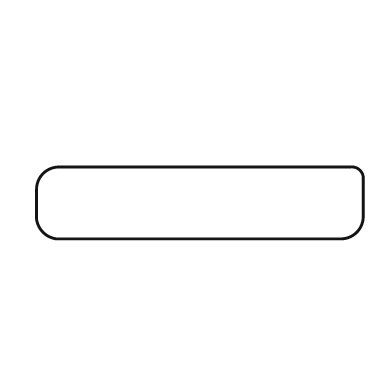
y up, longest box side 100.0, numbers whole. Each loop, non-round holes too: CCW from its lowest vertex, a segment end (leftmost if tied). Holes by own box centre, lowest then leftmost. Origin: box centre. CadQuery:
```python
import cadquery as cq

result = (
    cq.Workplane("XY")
    .moveTo(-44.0, -11.0)
    .lineTo(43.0, -11.0)
    .threePointArc((48.0, -9.0), (50.0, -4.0))
    .lineTo(50.0, 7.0)
    .threePointArc((49.0, 10.0), (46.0, 11.0))
    .lineTo(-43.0, 11.0)
    .threePointArc((-48.0, 9.0), (-50.0, 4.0))
    .lineTo(-50.0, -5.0)
    .threePointArc((-48.0, -9.0), (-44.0, -11.0))
    .close()
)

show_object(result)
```